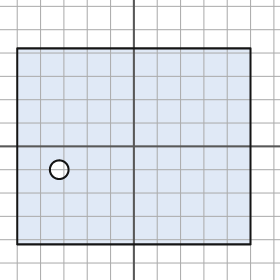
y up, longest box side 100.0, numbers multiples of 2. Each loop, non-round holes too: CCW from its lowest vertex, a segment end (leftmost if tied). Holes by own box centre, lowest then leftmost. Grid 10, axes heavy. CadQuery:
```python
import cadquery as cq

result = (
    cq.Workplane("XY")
    .moveTo(-50.0, -42.0)
    .lineTo(50.0, -42.0)
    .lineTo(50.0, 42.0)
    .lineTo(-50.0, 42.0)
    .close()
    .moveTo(-32.0, -10.0)
    .circle(4.0)
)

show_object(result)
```